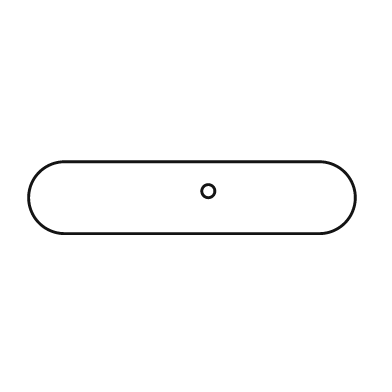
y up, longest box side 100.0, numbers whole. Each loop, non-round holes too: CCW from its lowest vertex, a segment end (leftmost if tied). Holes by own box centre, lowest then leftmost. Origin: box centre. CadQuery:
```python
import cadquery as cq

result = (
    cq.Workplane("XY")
    .moveTo(-39.0, -11.0)
    .lineTo(39.0, -11.0)
    .threePointArc((50.0, 0.0), (39.0, 11.0))
    .lineTo(-39.0, 11.0)
    .threePointArc((-50.0, 0.0), (-39.0, -11.0))
    .close()
    .moveTo(5.0, 2.0)
    .circle(2.0)
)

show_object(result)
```